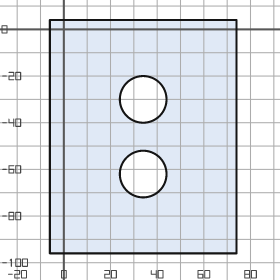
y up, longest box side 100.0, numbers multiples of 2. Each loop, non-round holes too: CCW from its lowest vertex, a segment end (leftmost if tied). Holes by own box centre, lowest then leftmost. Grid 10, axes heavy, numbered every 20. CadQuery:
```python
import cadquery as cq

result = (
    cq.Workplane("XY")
    .moveTo(-6.0, -96.0)
    .lineTo(74.0, -96.0)
    .lineTo(74.0, 4.0)
    .lineTo(-6.0, 4.0)
    .close()
    .moveTo(34.0, -62.0)
    .circle(10.0)
    .moveTo(34.0, -30.0)
    .circle(10.0)
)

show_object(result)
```